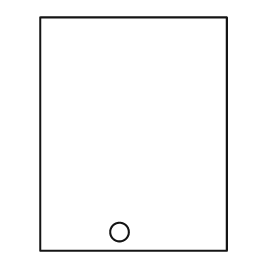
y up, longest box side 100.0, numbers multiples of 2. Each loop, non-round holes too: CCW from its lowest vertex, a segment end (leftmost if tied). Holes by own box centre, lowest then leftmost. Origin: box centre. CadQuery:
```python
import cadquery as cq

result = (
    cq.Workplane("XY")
    .moveTo(-40.0, -50.0)
    .lineTo(40.0, -50.0)
    .lineTo(40.0, 50.0)
    .lineTo(-40.0, 50.0)
    .close()
    .moveTo(-6.0, -42.0)
    .circle(4.0)
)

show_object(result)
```